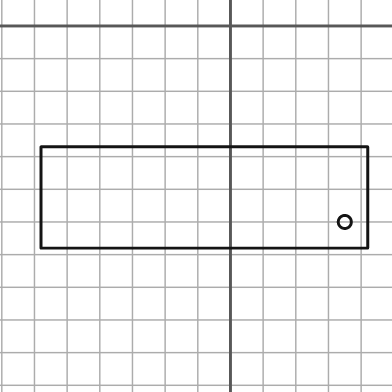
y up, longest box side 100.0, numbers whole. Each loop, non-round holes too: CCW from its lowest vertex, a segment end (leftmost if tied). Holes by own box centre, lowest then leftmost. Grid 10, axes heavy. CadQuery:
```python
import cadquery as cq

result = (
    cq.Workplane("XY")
    .moveTo(-58.0, -68.0)
    .lineTo(42.0, -68.0)
    .lineTo(42.0, -37.0)
    .lineTo(-58.0, -37.0)
    .close()
    .moveTo(35.0, -60.0)
    .circle(2.0)
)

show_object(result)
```